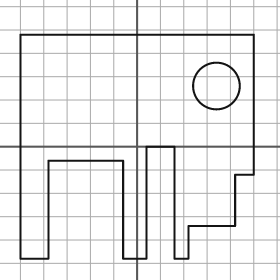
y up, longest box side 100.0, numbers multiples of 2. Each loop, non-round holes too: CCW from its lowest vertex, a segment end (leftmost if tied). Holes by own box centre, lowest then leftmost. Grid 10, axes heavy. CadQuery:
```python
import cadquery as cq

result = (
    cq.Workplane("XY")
    .moveTo(-50.0, -48.0)
    .lineTo(-38.0, -48.0)
    .lineTo(-38.0, -6.0)
    .lineTo(-6.0, -6.0)
    .lineTo(-6.0, -48.0)
    .lineTo(4.0, -48.0)
    .lineTo(4.0, 0.0)
    .lineTo(16.0, 0.0)
    .lineTo(16.0, -48.0)
    .lineTo(22.0, -48.0)
    .lineTo(22.0, -34.0)
    .lineTo(42.0, -34.0)
    .lineTo(42.0, -12.0)
    .lineTo(50.0, -12.0)
    .lineTo(50.0, 48.0)
    .lineTo(-50.0, 48.0)
    .close()
    .moveTo(34.0, 26.0)
    .circle(10.0)
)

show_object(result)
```